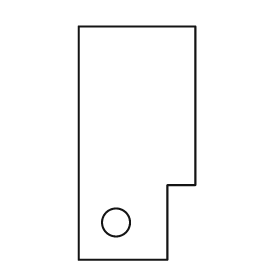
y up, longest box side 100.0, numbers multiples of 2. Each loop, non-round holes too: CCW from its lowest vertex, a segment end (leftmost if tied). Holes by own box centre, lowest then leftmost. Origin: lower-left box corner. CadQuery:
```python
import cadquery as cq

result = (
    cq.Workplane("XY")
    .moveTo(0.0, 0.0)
    .lineTo(38.0, 0.0)
    .lineTo(38.0, 32.0)
    .lineTo(50.0, 32.0)
    .lineTo(50.0, 100.0)
    .lineTo(0.0, 100.0)
    .close()
    .moveTo(16.0, 16.0)
    .circle(6.0)
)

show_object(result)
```